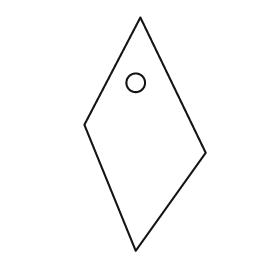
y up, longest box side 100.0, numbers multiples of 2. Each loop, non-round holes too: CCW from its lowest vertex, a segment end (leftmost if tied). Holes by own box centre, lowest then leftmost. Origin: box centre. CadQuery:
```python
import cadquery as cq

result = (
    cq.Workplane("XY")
    .moveTo(-4.0, -50.0)
    .lineTo(26.0, -8.0)
    .lineTo(-2.0, 50.0)
    .lineTo(-26.0, 4.0)
    .close()
    .moveTo(-4.0, 22.0)
    .circle(4.0)
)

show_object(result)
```